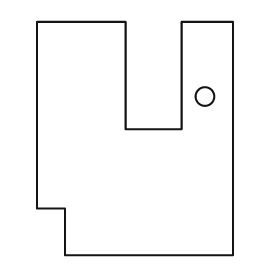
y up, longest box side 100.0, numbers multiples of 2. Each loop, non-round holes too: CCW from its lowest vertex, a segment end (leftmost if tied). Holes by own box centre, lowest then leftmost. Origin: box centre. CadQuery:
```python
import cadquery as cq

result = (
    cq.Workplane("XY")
    .moveTo(-30.0, -50.0)
    .lineTo(42.0, -50.0)
    .lineTo(42.0, 50.0)
    .lineTo(20.0, 50.0)
    .lineTo(20.0, 4.0)
    .lineTo(-4.0, 4.0)
    .lineTo(-4.0, 50.0)
    .lineTo(-42.0, 50.0)
    .lineTo(-42.0, -30.0)
    .lineTo(-30.0, -30.0)
    .close()
    .moveTo(30.0, 18.0)
    .circle(4.0)
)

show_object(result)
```